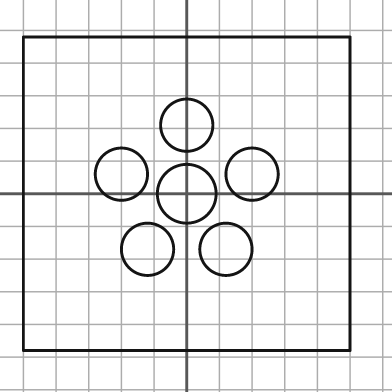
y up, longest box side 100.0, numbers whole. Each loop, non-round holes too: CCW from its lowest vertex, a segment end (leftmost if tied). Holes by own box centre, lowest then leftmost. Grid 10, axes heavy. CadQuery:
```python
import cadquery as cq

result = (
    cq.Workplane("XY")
    .moveTo(-50.0, -48.0)
    .lineTo(50.0, -48.0)
    .lineTo(50.0, 48.0)
    .lineTo(-50.0, 48.0)
    .close()
    .moveTo(-12.0, -17.0)
    .circle(8.0)
    .moveTo(12.0, -17.0)
    .circle(8.0)
    .moveTo(0.0, 0.0)
    .circle(9.0)
    .moveTo(-20.0, 6.0)
    .circle(8.0)
    .moveTo(20.0, 6.0)
    .circle(8.0)
    .moveTo(0.0, 21.0)
    .circle(8.0)
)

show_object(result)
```